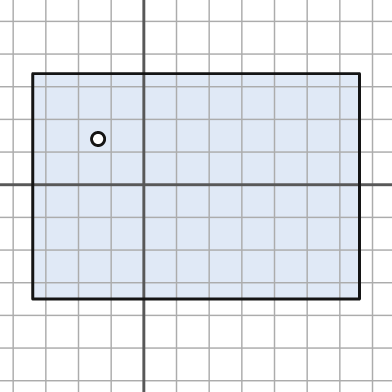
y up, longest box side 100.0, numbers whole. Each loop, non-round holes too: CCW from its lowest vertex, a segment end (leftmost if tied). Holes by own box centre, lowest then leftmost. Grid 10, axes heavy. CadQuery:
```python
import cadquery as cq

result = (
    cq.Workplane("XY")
    .moveTo(-34.0, -35.0)
    .lineTo(66.0, -35.0)
    .lineTo(66.0, 34.0)
    .lineTo(-34.0, 34.0)
    .close()
    .moveTo(-14.0, 14.0)
    .circle(2.0)
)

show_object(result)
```